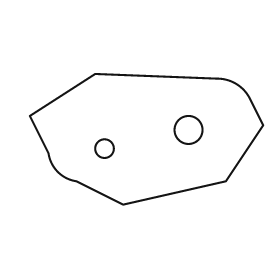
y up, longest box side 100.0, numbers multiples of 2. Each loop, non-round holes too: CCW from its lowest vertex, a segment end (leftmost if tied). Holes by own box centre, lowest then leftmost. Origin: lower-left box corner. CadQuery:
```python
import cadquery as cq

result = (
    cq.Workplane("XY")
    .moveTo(40.0, 0.0)
    .lineTo(84.0, 10.0)
    .lineTo(100.0, 34.0)
    .lineTo(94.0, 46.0)
    .threePointArc((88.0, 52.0), (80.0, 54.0))
    .lineTo(28.0, 56.0)
    .lineTo(0.0, 38.0)
    .lineTo(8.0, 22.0)
    .threePointArc((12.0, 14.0), (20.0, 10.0))
    .close()
    .moveTo(32.0, 24.0)
    .circle(4.0)
    .moveTo(68.0, 32.0)
    .circle(6.0)
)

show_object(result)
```